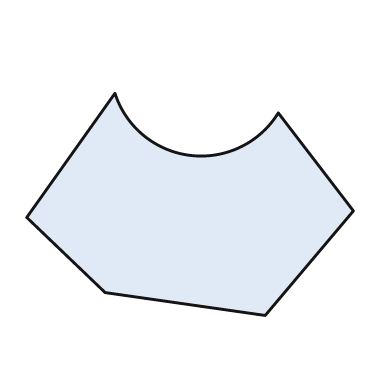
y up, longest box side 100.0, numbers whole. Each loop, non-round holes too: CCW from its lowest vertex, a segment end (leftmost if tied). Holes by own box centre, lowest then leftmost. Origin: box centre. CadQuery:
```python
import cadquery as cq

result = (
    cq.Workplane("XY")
    .moveTo(23.0, -34.0)
    .lineTo(50.0, -2.0)
    .lineTo(27.0, 28.0)
    .threePointArc((0.0, 15.0), (-23.0, 34.0))
    .lineTo(-50.0, -4.0)
    .lineTo(-26.0, -27.0)
    .close()
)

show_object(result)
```